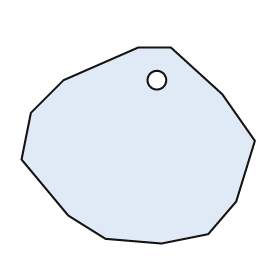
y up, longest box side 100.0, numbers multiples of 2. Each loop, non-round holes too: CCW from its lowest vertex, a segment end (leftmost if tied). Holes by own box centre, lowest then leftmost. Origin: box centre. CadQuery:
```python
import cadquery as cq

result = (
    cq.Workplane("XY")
    .moveTo(10.0, -42.0)
    .lineTo(30.0, -38.0)
    .lineTo(42.0, -24.0)
    .lineTo(50.0, 2.0)
    .lineTo(36.0, 22.0)
    .lineTo(14.0, 42.0)
    .lineTo(0.0, 42.0)
    .lineTo(-32.0, 28.0)
    .lineTo(-46.0, 14.0)
    .lineTo(-50.0, -6.0)
    .lineTo(-30.0, -30.0)
    .lineTo(-14.0, -40.0)
    .close()
    .moveTo(8.0, 28.0)
    .circle(4.0)
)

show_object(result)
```